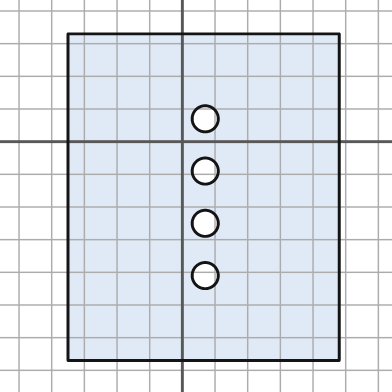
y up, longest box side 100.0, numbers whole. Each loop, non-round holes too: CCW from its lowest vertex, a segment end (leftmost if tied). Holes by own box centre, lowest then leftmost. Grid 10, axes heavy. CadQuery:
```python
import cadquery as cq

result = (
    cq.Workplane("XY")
    .moveTo(-35.0, -67.0)
    .lineTo(48.0, -67.0)
    .lineTo(48.0, 33.0)
    .lineTo(-35.0, 33.0)
    .close()
    .moveTo(7.0, -41.0)
    .circle(4.0)
    .moveTo(7.0, -25.0)
    .circle(4.0)
    .moveTo(7.0, -9.0)
    .circle(4.0)
    .moveTo(7.0, 7.0)
    .circle(4.0)
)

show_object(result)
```